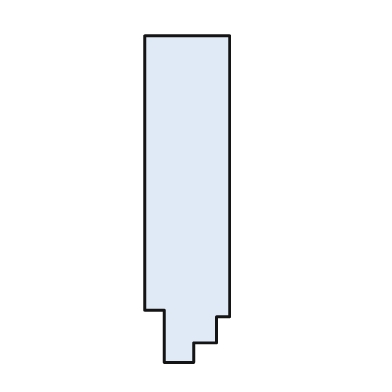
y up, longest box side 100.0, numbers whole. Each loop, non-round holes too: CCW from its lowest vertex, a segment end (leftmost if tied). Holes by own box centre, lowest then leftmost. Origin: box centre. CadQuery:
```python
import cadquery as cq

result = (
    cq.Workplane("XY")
    .moveTo(-7.0, -50.0)
    .lineTo(2.0, -50.0)
    .lineTo(2.0, -44.0)
    .lineTo(9.0, -44.0)
    .lineTo(9.0, -36.0)
    .lineTo(13.0, -36.0)
    .lineTo(13.0, 50.0)
    .lineTo(-13.0, 50.0)
    .lineTo(-13.0, -34.0)
    .lineTo(-7.0, -34.0)
    .close()
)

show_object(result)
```